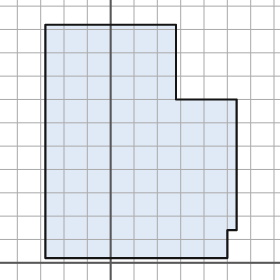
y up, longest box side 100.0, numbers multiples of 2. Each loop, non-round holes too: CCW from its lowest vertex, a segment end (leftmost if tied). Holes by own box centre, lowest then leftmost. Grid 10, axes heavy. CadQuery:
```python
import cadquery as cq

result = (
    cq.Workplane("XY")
    .moveTo(-28.0, 2.0)
    .lineTo(50.0, 2.0)
    .lineTo(50.0, 14.0)
    .lineTo(54.0, 14.0)
    .lineTo(54.0, 70.0)
    .lineTo(28.0, 70.0)
    .lineTo(28.0, 102.0)
    .lineTo(-28.0, 102.0)
    .close()
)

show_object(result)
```